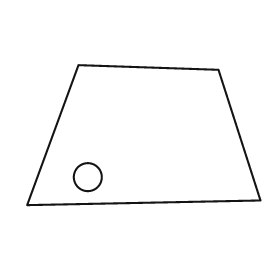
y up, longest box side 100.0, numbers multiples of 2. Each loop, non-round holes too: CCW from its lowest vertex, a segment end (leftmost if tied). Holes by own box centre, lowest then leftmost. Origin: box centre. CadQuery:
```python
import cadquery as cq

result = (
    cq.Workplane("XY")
    .moveTo(-50.0, -30.0)
    .lineTo(50.0, -28.0)
    .lineTo(32.0, 28.0)
    .lineTo(-28.0, 30.0)
    .close()
    .moveTo(-24.0, -18.0)
    .circle(6.0)
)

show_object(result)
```